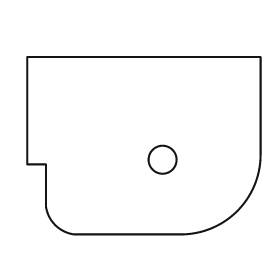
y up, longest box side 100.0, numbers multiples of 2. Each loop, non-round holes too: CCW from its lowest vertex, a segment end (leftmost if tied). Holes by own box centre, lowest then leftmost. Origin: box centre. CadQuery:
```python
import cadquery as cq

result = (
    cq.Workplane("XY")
    .moveTo(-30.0, -38.0)
    .lineTo(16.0, -38.0)
    .threePointArc((40.0, -28.0), (50.0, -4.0))
    .lineTo(50.0, 38.0)
    .lineTo(-50.0, 38.0)
    .lineTo(-50.0, -8.0)
    .lineTo(-42.0, -8.0)
    .lineTo(-42.0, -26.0)
    .threePointArc((-38.0, -34.0), (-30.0, -38.0))
    .close()
    .moveTo(8.0, -6.0)
    .circle(6.0)
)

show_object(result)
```